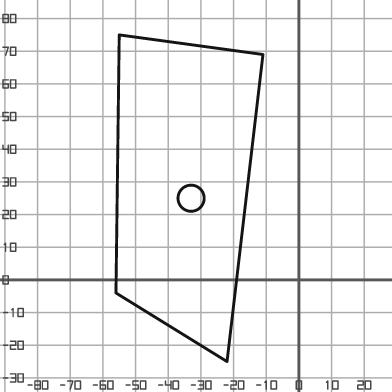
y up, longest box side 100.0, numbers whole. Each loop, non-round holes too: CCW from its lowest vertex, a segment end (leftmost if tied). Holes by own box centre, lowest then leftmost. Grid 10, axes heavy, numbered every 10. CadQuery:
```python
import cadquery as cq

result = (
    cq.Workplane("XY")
    .moveTo(-22.0, -25.0)
    .lineTo(-11.0, 69.0)
    .lineTo(-55.0, 75.0)
    .lineTo(-56.0, -4.0)
    .close()
    .moveTo(-33.0, 25.0)
    .circle(4.0)
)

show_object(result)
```